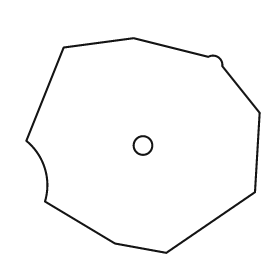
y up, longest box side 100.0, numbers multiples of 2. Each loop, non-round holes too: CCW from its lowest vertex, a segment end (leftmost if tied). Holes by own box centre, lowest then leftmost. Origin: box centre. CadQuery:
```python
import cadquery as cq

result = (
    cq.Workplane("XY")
    .moveTo(10.0, -46.0)
    .lineTo(48.0, -20.0)
    .lineTo(50.0, 14.0)
    .lineTo(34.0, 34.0)
    .threePointArc((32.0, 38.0), (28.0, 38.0))
    .lineTo(-4.0, 46.0)
    .lineTo(-34.0, 42.0)
    .lineTo(-50.0, 2.0)
    .threePointArc((-42.0, -10.0), (-42.0, -24.0))
    .lineTo(-12.0, -42.0)
    .close()
    .moveTo(0.0, 0.0)
    .circle(4.0)
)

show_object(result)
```